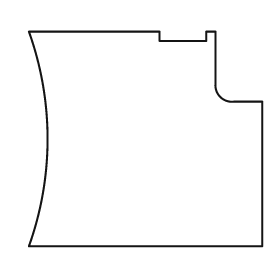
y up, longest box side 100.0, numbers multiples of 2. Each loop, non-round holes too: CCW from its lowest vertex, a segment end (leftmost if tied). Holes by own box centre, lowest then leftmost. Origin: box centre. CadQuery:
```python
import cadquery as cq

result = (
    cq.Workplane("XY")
    .moveTo(-50.0, -46.0)
    .lineTo(50.0, -46.0)
    .lineTo(50.0, 16.0)
    .lineTo(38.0, 16.0)
    .threePointArc((32.0, 18.0), (30.0, 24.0))
    .lineTo(30.0, 46.0)
    .lineTo(26.0, 46.0)
    .lineTo(26.0, 42.0)
    .lineTo(6.0, 42.0)
    .lineTo(6.0, 46.0)
    .lineTo(-50.0, 46.0)
    .threePointArc((-42.0, 0.0), (-50.0, -46.0))
    .close()
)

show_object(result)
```